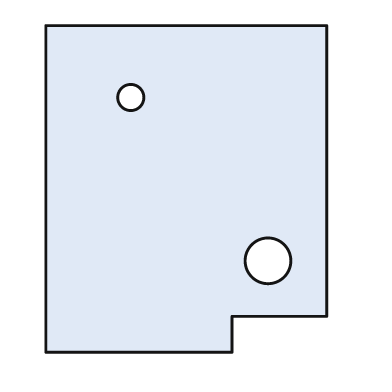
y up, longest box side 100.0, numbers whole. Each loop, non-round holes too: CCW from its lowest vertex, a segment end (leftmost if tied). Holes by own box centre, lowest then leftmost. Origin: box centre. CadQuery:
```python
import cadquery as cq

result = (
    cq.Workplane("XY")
    .moveTo(-43.0, -50.0)
    .lineTo(14.0, -50.0)
    .lineTo(14.0, -39.0)
    .lineTo(43.0, -39.0)
    .lineTo(43.0, 50.0)
    .lineTo(-43.0, 50.0)
    .close()
    .moveTo(25.0, -22.0)
    .circle(7.0)
    .moveTo(-17.0, 28.0)
    .circle(4.0)
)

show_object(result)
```